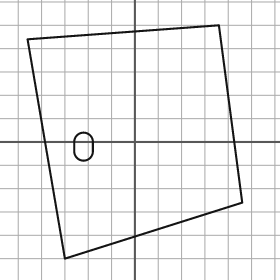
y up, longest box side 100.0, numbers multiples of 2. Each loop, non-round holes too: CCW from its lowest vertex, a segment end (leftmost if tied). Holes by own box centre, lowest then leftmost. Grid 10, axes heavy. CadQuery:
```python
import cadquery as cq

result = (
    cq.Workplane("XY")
    .moveTo(-30.0, -50.0)
    .lineTo(46.0, -26.0)
    .lineTo(36.0, 50.0)
    .lineTo(-46.0, 44.0)
    .close()
    .moveTo(-26.0, -4.0)
    .threePointArc((-22.0, -8.0), (-18.0, -4.0))
    .lineTo(-18.0, 0.0)
    .threePointArc((-22.0, 4.0), (-26.0, 0.0))
    .close()
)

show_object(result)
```